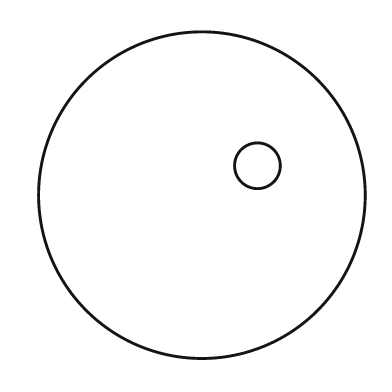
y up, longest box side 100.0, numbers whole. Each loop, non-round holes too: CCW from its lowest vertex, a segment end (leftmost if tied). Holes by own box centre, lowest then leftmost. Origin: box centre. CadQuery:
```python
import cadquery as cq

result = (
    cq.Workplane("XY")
    .moveTo(0.0, 0.0)
    .circle(50.0)
    .moveTo(17.0, 9.0)
    .circle(7.0)
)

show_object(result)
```